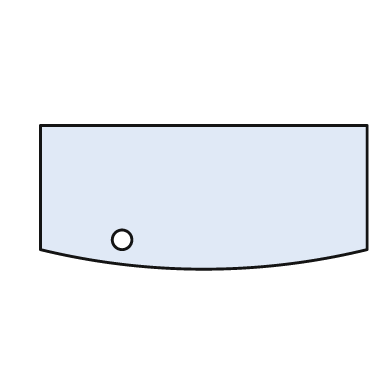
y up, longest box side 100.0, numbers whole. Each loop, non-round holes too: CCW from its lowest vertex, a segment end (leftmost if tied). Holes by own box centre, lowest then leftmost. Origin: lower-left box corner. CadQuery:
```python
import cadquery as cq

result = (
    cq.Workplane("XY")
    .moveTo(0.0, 6.0)
    .threePointArc((50.0, 0.0), (100.0, 6.0))
    .lineTo(100.0, 44.0)
    .lineTo(0.0, 44.0)
    .close()
    .moveTo(25.0, 9.0)
    .circle(3.0)
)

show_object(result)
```